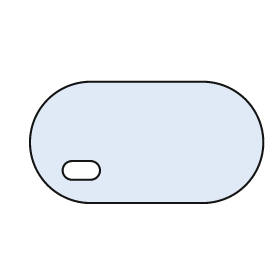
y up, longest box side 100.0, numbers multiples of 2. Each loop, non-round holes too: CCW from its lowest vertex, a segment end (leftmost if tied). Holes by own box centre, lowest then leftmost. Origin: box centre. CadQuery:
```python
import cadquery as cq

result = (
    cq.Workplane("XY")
    .moveTo(-24.0, -26.0)
    .lineTo(24.0, -26.0)
    .threePointArc((50.0, 0.0), (24.0, 26.0))
    .lineTo(-24.0, 26.0)
    .threePointArc((-50.0, 0.0), (-24.0, -26.0))
    .close()
    .moveTo(-32.0, -16.0)
    .lineTo(-24.0, -16.0)
    .threePointArc((-20.0, -12.0), (-24.0, -8.0))
    .lineTo(-32.0, -8.0)
    .threePointArc((-36.0, -12.0), (-32.0, -16.0))
    .close()
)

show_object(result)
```